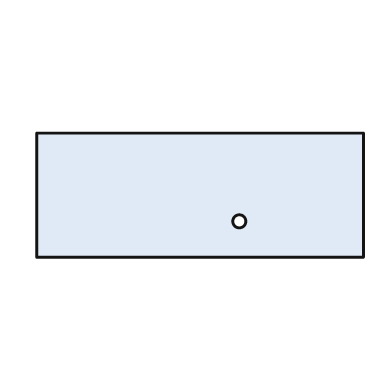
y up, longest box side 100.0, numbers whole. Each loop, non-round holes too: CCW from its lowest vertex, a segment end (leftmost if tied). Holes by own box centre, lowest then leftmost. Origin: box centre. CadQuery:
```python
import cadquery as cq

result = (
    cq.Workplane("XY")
    .moveTo(-50.0, -19.0)
    .lineTo(50.0, -19.0)
    .lineTo(50.0, 19.0)
    .lineTo(-50.0, 19.0)
    .close()
    .moveTo(12.0, -8.0)
    .circle(2.0)
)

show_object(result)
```